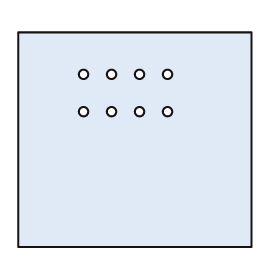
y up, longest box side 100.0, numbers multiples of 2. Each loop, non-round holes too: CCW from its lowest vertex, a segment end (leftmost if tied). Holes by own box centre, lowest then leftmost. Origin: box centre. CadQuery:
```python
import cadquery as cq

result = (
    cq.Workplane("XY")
    .moveTo(-50.0, -46.0)
    .lineTo(50.0, -46.0)
    .lineTo(50.0, 46.0)
    .lineTo(-50.0, 46.0)
    .close()
    .moveTo(-22.0, 12.0)
    .circle(2.0)
    .moveTo(-10.0, 12.0)
    .circle(2.0)
    .moveTo(2.0, 12.0)
    .circle(2.0)
    .moveTo(14.0, 12.0)
    .circle(2.0)
    .moveTo(-22.0, 28.0)
    .circle(2.0)
    .moveTo(-10.0, 28.0)
    .circle(2.0)
    .moveTo(2.0, 28.0)
    .circle(2.0)
    .moveTo(14.0, 28.0)
    .circle(2.0)
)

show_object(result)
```